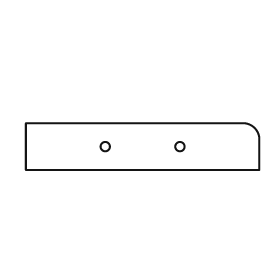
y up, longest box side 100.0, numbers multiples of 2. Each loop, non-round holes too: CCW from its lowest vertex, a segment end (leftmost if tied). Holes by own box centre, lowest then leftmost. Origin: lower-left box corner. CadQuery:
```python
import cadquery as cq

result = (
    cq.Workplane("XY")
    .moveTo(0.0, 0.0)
    .lineTo(100.0, 0.0)
    .lineTo(100.0, 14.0)
    .threePointArc((98.0, 18.0), (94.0, 20.0))
    .lineTo(0.0, 20.0)
    .close()
    .moveTo(34.0, 10.0)
    .circle(2.0)
    .moveTo(66.0, 10.0)
    .circle(2.0)
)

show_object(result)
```